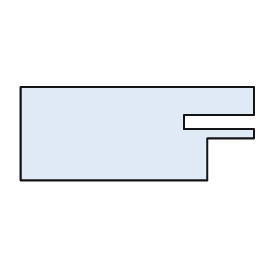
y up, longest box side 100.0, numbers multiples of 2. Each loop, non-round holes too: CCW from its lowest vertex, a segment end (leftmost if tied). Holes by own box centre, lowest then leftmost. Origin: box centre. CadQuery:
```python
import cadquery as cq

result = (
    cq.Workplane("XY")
    .moveTo(-50.0, -20.0)
    .lineTo(30.0, -20.0)
    .lineTo(30.0, -2.0)
    .lineTo(50.0, -2.0)
    .lineTo(50.0, 2.0)
    .lineTo(20.0, 2.0)
    .lineTo(20.0, 8.0)
    .lineTo(50.0, 8.0)
    .lineTo(50.0, 20.0)
    .lineTo(-50.0, 20.0)
    .close()
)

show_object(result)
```